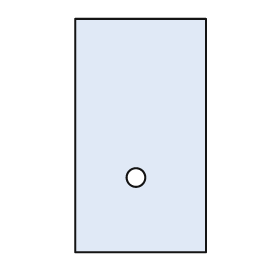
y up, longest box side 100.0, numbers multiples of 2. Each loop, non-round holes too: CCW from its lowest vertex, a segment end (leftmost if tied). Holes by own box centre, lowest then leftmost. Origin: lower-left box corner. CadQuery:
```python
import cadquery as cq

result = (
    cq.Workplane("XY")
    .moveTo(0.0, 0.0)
    .lineTo(56.0, 0.0)
    .lineTo(56.0, 100.0)
    .lineTo(0.0, 100.0)
    .close()
    .moveTo(26.0, 32.0)
    .circle(4.0)
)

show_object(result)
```